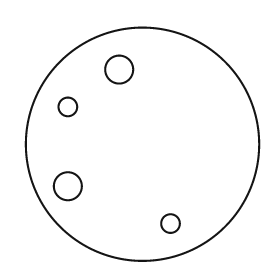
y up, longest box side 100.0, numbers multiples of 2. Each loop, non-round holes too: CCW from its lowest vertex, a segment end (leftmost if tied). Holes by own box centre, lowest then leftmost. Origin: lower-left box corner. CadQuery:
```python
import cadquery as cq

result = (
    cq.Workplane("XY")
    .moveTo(50.0, 50.0)
    .circle(50.0)
    .moveTo(62.0, 16.0)
    .circle(4.0)
    .moveTo(18.0, 32.0)
    .circle(6.0)
    .moveTo(18.0, 66.0)
    .circle(4.0)
    .moveTo(40.0, 82.0)
    .circle(6.0)
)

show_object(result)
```